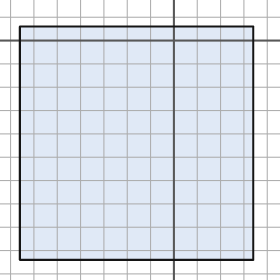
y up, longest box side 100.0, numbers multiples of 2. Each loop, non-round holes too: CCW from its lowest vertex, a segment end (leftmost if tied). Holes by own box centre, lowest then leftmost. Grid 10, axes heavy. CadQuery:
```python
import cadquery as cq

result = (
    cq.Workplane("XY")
    .moveTo(-66.0, -94.0)
    .lineTo(34.0, -94.0)
    .lineTo(34.0, 6.0)
    .lineTo(-66.0, 6.0)
    .close()
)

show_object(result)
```